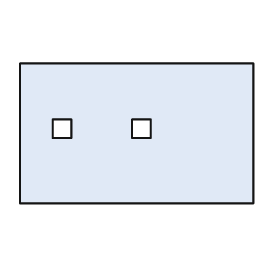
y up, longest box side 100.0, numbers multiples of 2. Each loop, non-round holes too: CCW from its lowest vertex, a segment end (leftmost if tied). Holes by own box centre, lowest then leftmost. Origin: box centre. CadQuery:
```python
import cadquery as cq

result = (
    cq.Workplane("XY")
    .moveTo(-50.0, -30.0)
    .lineTo(50.0, -30.0)
    .lineTo(50.0, 30.0)
    .lineTo(-50.0, 30.0)
    .close()
    .moveTo(-36.0, -2.0)
    .lineTo(-28.0, -2.0)
    .lineTo(-28.0, 6.0)
    .lineTo(-36.0, 6.0)
    .close()
    .moveTo(-2.0, -2.0)
    .lineTo(6.0, -2.0)
    .lineTo(6.0, 6.0)
    .lineTo(-2.0, 6.0)
    .close()
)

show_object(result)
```